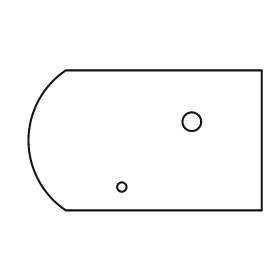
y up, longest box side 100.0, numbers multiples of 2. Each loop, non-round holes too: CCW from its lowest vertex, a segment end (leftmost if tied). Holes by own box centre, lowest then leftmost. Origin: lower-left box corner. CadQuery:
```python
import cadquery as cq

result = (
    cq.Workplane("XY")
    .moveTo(16.0, 0.0)
    .lineTo(100.0, 0.0)
    .lineTo(100.0, 60.0)
    .lineTo(16.0, 60.0)
    .threePointArc((0.0, 30.0), (16.0, 0.0))
    .close()
    .moveTo(40.0, 10.0)
    .circle(2.0)
    .moveTo(70.0, 38.0)
    .circle(4.0)
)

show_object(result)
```